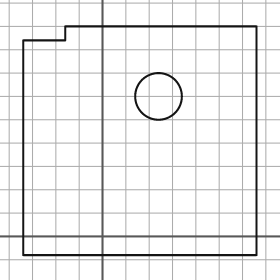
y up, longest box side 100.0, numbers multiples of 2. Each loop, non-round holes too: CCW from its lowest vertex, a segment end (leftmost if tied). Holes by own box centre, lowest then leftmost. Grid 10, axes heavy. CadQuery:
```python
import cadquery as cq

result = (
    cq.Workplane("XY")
    .moveTo(-34.0, -8.0)
    .lineTo(66.0, -8.0)
    .lineTo(66.0, 90.0)
    .lineTo(-16.0, 90.0)
    .lineTo(-16.0, 84.0)
    .lineTo(-34.0, 84.0)
    .close()
    .moveTo(24.0, 60.0)
    .circle(10.0)
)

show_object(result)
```